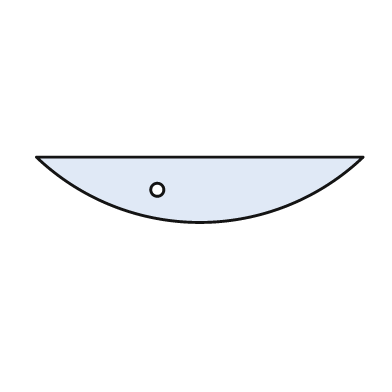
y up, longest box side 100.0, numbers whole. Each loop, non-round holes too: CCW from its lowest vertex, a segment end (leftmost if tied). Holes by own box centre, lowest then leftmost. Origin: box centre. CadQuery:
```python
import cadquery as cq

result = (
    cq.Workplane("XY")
    .moveTo(-50.0, 10.0)
    .threePointArc((0.0, -10.0), (50.0, 10.0))
    .close()
    .moveTo(-13.0, 0.0)
    .circle(2.0)
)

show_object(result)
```